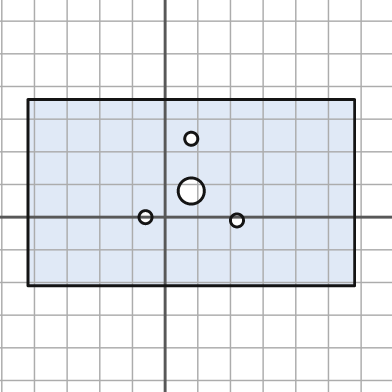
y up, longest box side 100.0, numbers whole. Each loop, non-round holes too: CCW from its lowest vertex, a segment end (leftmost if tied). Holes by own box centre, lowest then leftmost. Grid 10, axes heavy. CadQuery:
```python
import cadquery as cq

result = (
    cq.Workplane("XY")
    .moveTo(-42.0, -21.0)
    .lineTo(58.0, -21.0)
    .lineTo(58.0, 36.0)
    .lineTo(-42.0, 36.0)
    .close()
    .moveTo(22.0, -1.0)
    .circle(2.0)
    .moveTo(-6.0, 0.0)
    .circle(2.0)
    .moveTo(8.0, 8.0)
    .circle(4.0)
    .moveTo(8.0, 24.0)
    .circle(2.0)
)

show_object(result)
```